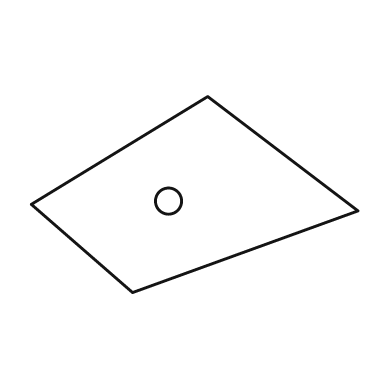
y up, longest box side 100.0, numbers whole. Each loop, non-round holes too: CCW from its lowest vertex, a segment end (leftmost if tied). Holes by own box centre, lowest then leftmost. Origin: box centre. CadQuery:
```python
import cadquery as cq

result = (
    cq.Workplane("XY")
    .moveTo(-19.0, -30.0)
    .lineTo(50.0, -5.0)
    .lineTo(4.0, 30.0)
    .lineTo(-50.0, -3.0)
    .close()
    .moveTo(-8.0, -2.0)
    .circle(4.0)
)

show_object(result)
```